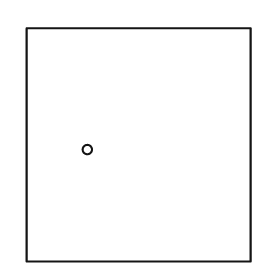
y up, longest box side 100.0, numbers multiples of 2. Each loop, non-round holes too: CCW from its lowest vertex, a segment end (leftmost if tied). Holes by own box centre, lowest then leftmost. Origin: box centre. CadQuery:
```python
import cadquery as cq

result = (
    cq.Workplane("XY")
    .moveTo(-48.0, -50.0)
    .lineTo(48.0, -50.0)
    .lineTo(48.0, 50.0)
    .lineTo(-48.0, 50.0)
    .close()
    .moveTo(-22.0, -2.0)
    .circle(2.0)
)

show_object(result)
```